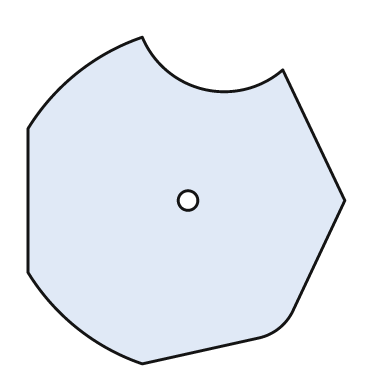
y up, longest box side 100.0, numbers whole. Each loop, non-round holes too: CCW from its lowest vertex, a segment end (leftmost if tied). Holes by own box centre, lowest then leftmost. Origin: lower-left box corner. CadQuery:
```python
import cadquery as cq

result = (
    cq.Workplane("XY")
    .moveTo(35.0, 0.0)
    .lineTo(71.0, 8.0)
    .threePointArc((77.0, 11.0), (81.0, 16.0))
    .lineTo(97.0, 50.0)
    .lineTo(78.0, 90.0)
    .threePointArc((54.0, 84.0), (35.0, 100.0))
    .threePointArc((15.0, 89.0), (0.0, 72.0))
    .lineTo(0.0, 28.0)
    .threePointArc((15.0, 11.0), (35.0, 0.0))
    .close()
    .moveTo(49.0, 50.0)
    .circle(3.0)
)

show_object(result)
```